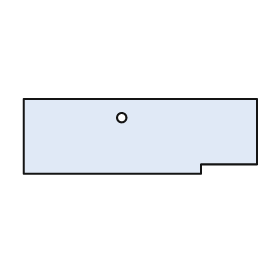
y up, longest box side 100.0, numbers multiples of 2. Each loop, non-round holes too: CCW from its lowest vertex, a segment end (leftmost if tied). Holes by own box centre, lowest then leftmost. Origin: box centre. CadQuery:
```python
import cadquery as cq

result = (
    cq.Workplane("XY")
    .moveTo(-50.0, -16.0)
    .lineTo(26.0, -16.0)
    .lineTo(26.0, -12.0)
    .lineTo(50.0, -12.0)
    .lineTo(50.0, 16.0)
    .lineTo(-50.0, 16.0)
    .close()
    .moveTo(-8.0, 8.0)
    .circle(2.0)
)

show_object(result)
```